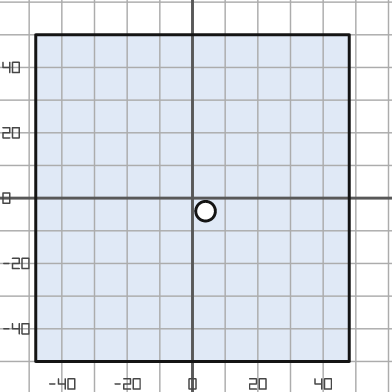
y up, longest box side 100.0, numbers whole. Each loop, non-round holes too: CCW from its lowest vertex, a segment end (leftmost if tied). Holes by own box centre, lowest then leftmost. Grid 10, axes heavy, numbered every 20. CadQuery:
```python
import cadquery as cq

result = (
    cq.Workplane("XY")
    .moveTo(-48.0, -50.0)
    .lineTo(48.0, -50.0)
    .lineTo(48.0, 50.0)
    .lineTo(-48.0, 50.0)
    .close()
    .moveTo(4.0, -4.0)
    .circle(3.0)
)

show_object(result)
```